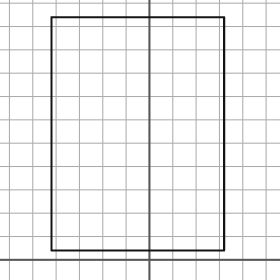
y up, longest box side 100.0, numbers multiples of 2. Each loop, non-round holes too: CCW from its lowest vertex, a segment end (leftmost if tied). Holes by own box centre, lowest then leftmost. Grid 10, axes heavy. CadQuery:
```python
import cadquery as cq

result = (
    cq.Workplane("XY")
    .moveTo(-42.0, 4.0)
    .lineTo(32.0, 4.0)
    .lineTo(32.0, 104.0)
    .lineTo(-42.0, 104.0)
    .close()
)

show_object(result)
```